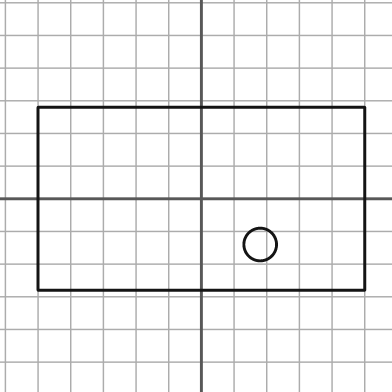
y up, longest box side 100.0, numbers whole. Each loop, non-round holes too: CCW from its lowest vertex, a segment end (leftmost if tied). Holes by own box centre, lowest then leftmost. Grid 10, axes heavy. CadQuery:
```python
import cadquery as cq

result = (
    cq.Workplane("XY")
    .moveTo(-50.0, -28.0)
    .lineTo(50.0, -28.0)
    .lineTo(50.0, 28.0)
    .lineTo(-50.0, 28.0)
    .close()
    .moveTo(18.0, -14.0)
    .circle(5.0)
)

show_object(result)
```